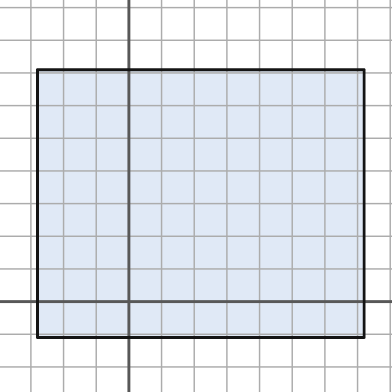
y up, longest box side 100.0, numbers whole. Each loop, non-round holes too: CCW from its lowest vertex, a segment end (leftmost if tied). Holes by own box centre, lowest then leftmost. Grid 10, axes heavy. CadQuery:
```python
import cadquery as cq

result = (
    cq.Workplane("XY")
    .moveTo(-28.0, -11.0)
    .lineTo(72.0, -11.0)
    .lineTo(72.0, 71.0)
    .lineTo(-28.0, 71.0)
    .close()
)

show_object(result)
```